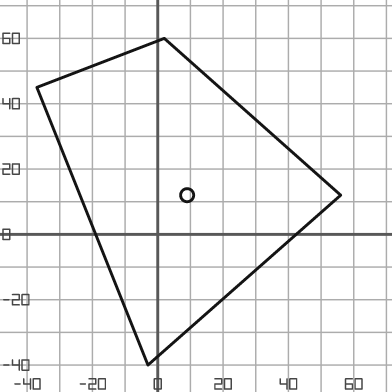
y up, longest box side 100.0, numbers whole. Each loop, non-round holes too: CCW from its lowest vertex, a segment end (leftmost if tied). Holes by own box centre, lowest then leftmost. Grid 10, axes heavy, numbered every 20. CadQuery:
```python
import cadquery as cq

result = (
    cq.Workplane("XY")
    .moveTo(-3.0, -40.0)
    .lineTo(56.0, 12.0)
    .lineTo(2.0, 60.0)
    .lineTo(-37.0, 45.0)
    .close()
    .moveTo(9.0, 12.0)
    .circle(2.0)
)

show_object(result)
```